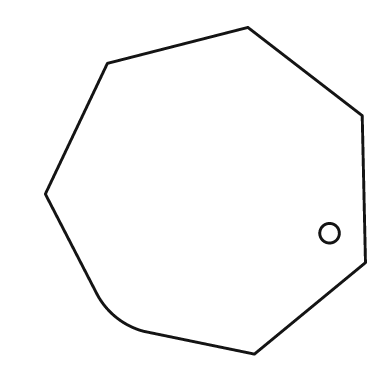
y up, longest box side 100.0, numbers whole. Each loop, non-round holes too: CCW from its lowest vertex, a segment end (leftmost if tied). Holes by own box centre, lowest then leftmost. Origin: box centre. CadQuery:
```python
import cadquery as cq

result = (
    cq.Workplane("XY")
    .moveTo(15.0, -50.0)
    .lineTo(49.0, -22.0)
    .lineTo(48.0, 23.0)
    .lineTo(13.0, 50.0)
    .lineTo(-30.0, 39.0)
    .lineTo(-49.0, -1.0)
    .lineTo(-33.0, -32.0)
    .threePointArc((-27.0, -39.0), (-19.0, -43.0))
    .close()
    .moveTo(38.0, -13.0)
    .circle(3.0)
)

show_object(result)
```